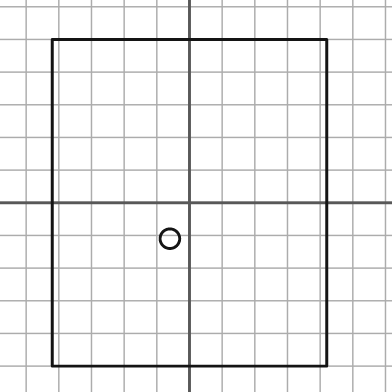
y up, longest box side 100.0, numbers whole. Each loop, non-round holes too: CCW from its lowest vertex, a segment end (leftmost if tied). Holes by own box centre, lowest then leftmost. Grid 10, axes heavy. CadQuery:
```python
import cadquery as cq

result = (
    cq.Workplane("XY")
    .moveTo(-42.0, -50.0)
    .lineTo(42.0, -50.0)
    .lineTo(42.0, 50.0)
    .lineTo(-42.0, 50.0)
    .close()
    .moveTo(-6.0, -11.0)
    .circle(3.0)
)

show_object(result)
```